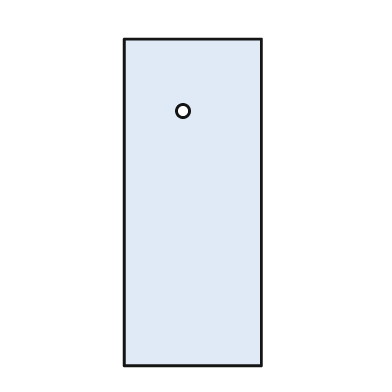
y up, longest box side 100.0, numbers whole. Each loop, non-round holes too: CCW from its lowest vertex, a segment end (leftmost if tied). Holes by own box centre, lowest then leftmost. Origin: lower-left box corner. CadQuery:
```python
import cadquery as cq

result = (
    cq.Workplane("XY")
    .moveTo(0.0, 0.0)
    .lineTo(42.0, 0.0)
    .lineTo(42.0, 100.0)
    .lineTo(0.0, 100.0)
    .close()
    .moveTo(18.0, 78.0)
    .circle(2.0)
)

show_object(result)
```